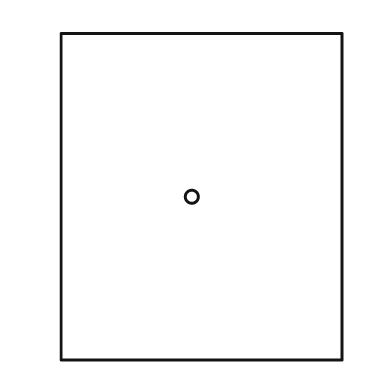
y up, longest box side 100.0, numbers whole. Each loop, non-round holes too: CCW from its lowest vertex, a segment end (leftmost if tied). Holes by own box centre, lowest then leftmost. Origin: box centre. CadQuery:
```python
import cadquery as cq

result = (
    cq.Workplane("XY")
    .moveTo(-43.0, -50.0)
    .lineTo(43.0, -50.0)
    .lineTo(43.0, 50.0)
    .lineTo(-43.0, 50.0)
    .close()
    .moveTo(-3.0, 0.0)
    .circle(2.0)
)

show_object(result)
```